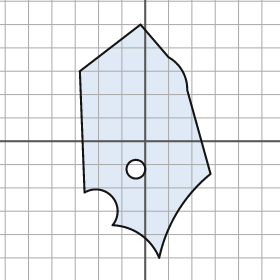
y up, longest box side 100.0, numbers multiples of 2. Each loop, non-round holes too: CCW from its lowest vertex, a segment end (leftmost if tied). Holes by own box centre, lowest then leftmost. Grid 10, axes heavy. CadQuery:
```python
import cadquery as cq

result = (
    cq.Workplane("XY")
    .moveTo(6.0, -50.0)
    .threePointArc((14.0, -30.0), (28.0, -14.0))
    .lineTo(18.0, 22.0)
    .threePointArc((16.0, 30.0), (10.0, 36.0))
    .lineTo(-2.0, 50.0)
    .lineTo(-28.0, 30.0)
    .lineTo(-26.0, -22.0)
    .threePointArc((-14.0, -24.0), (-14.0, -36.0))
    .threePointArc((-2.0, -40.0), (6.0, -50.0))
    .close()
    .moveTo(-4.0, -12.0)
    .circle(4.0)
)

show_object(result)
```